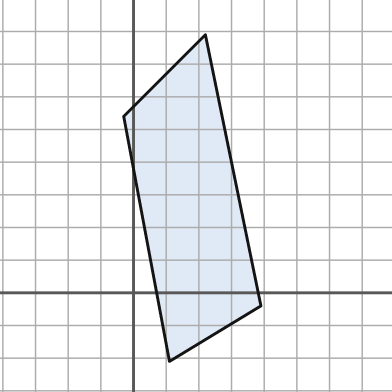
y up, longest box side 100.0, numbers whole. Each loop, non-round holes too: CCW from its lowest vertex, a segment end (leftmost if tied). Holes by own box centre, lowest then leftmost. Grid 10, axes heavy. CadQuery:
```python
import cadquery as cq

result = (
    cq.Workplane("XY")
    .moveTo(11.0, -21.0)
    .lineTo(39.0, -4.0)
    .lineTo(22.0, 79.0)
    .lineTo(-3.0, 54.0)
    .close()
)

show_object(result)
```